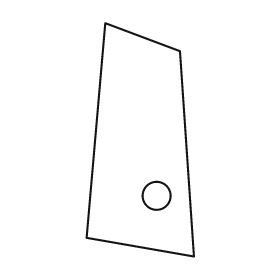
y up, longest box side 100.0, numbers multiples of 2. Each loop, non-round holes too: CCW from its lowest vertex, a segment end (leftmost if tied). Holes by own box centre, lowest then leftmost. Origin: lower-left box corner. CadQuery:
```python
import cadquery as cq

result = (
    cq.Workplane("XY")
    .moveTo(46.0, 0.0)
    .lineTo(40.0, 88.0)
    .lineTo(8.0, 100.0)
    .lineTo(0.0, 8.0)
    .close()
    .moveTo(30.0, 26.0)
    .circle(6.0)
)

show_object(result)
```